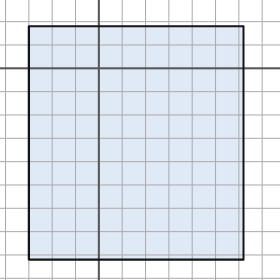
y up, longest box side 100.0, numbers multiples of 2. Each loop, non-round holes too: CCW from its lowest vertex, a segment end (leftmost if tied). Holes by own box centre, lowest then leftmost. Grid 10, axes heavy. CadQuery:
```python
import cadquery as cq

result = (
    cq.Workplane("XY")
    .moveTo(-30.0, -82.0)
    .lineTo(62.0, -82.0)
    .lineTo(62.0, 18.0)
    .lineTo(-30.0, 18.0)
    .close()
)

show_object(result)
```